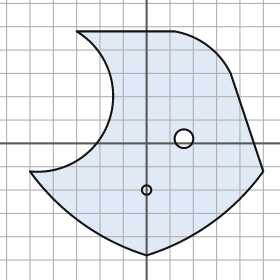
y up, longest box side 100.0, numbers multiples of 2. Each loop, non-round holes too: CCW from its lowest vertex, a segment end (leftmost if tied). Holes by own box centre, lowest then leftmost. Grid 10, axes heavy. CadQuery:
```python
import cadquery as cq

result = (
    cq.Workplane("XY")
    .moveTo(0.0, -48.0)
    .threePointArc((28.0, -34.0), (50.0, -12.0))
    .lineTo(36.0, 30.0)
    .threePointArc((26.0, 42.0), (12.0, 48.0))
    .lineTo(-30.0, 48.0)
    .threePointArc((-16.0, 10.0), (-50.0, -12.0))
    .threePointArc((-28.0, -34.0), (0.0, -48.0))
    .close()
    .moveTo(0.0, -20.0)
    .circle(2.0)
    .moveTo(16.0, 2.0)
    .circle(4.0)
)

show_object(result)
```